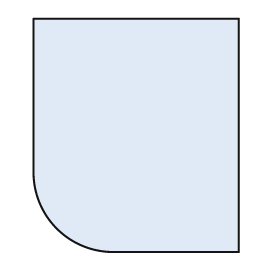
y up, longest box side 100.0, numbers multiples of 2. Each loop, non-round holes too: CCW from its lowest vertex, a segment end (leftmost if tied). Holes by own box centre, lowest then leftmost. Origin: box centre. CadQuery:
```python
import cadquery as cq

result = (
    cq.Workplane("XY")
    .moveTo(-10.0, -50.0)
    .lineTo(44.0, -50.0)
    .lineTo(44.0, 50.0)
    .lineTo(-44.0, 50.0)
    .lineTo(-44.0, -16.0)
    .threePointArc((-34.0, -40.0), (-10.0, -50.0))
    .close()
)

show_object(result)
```